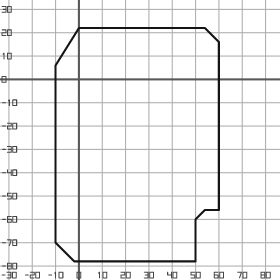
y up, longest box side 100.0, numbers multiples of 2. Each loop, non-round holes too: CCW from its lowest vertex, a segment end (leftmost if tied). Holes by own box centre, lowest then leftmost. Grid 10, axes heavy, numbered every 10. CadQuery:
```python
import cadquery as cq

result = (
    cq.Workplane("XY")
    .moveTo(-2.0, -78.0)
    .lineTo(50.0, -78.0)
    .lineTo(50.0, -60.0)
    .lineTo(54.0, -56.0)
    .lineTo(60.0, -56.0)
    .lineTo(60.0, 16.0)
    .lineTo(54.0, 22.0)
    .lineTo(0.0, 22.0)
    .lineTo(-10.0, 6.0)
    .lineTo(-10.0, -70.0)
    .close()
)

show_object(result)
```